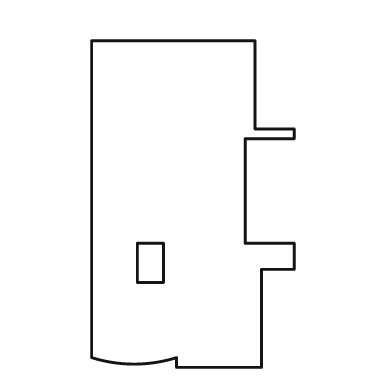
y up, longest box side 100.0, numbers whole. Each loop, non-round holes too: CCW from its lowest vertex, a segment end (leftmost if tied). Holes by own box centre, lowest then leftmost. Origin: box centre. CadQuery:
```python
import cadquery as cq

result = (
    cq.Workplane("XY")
    .moveTo(-5.0, -50.0)
    .lineTo(21.0, -50.0)
    .lineTo(21.0, -20.0)
    .lineTo(31.0, -20.0)
    .lineTo(31.0, -12.0)
    .lineTo(16.0, -12.0)
    .lineTo(16.0, 20.0)
    .lineTo(31.0, 20.0)
    .lineTo(31.0, 23.0)
    .lineTo(19.0, 23.0)
    .lineTo(19.0, 50.0)
    .lineTo(-31.0, 50.0)
    .lineTo(-31.0, -47.0)
    .threePointArc((-18.0, -49.0), (-5.0, -47.0))
    .close()
    .moveTo(-17.0, -24.0)
    .lineTo(-9.0, -24.0)
    .lineTo(-9.0, -12.0)
    .lineTo(-17.0, -12.0)
    .close()
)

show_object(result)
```